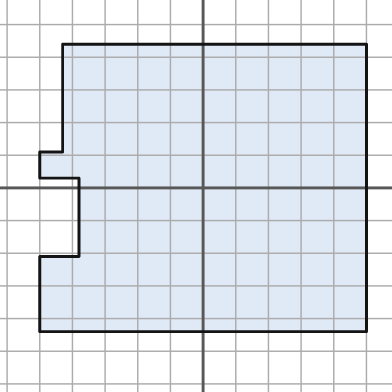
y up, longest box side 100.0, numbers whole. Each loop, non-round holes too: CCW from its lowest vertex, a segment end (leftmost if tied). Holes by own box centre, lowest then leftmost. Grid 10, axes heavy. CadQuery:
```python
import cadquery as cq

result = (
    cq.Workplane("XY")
    .moveTo(-50.0, -44.0)
    .lineTo(50.0, -44.0)
    .lineTo(50.0, 44.0)
    .lineTo(-43.0, 44.0)
    .lineTo(-43.0, 11.0)
    .lineTo(-50.0, 11.0)
    .lineTo(-50.0, 3.0)
    .lineTo(-38.0, 3.0)
    .lineTo(-38.0, -21.0)
    .lineTo(-50.0, -21.0)
    .close()
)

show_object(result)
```